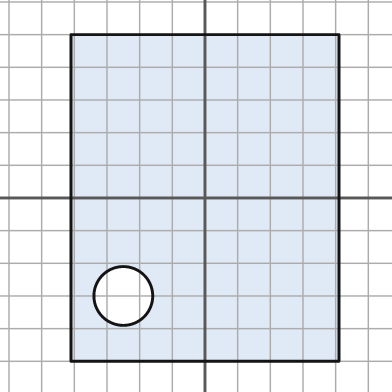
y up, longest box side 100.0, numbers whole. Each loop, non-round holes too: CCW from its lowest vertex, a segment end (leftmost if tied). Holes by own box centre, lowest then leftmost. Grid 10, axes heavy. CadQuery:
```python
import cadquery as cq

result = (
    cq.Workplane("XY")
    .moveTo(-41.0, -50.0)
    .lineTo(41.0, -50.0)
    .lineTo(41.0, 50.0)
    .lineTo(-41.0, 50.0)
    .close()
    .moveTo(-25.0, -30.0)
    .circle(9.0)
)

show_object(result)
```